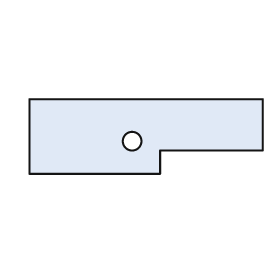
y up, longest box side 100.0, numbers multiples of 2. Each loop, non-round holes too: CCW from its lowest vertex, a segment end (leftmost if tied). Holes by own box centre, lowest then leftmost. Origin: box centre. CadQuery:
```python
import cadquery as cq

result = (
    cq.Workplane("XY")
    .moveTo(-50.0, -16.0)
    .lineTo(6.0, -16.0)
    .lineTo(6.0, -6.0)
    .lineTo(50.0, -6.0)
    .lineTo(50.0, 16.0)
    .lineTo(-50.0, 16.0)
    .close()
    .moveTo(-6.0, -2.0)
    .circle(4.0)
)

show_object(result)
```